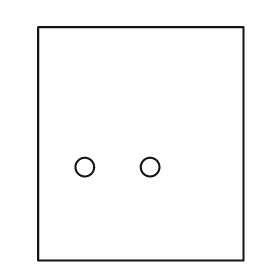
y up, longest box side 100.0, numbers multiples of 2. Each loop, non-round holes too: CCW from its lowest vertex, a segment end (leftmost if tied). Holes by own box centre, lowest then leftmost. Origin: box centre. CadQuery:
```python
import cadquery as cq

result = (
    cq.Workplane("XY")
    .moveTo(-44.0, -50.0)
    .lineTo(44.0, -50.0)
    .lineTo(44.0, 50.0)
    .lineTo(-44.0, 50.0)
    .close()
    .moveTo(-24.0, -10.0)
    .circle(4.0)
    .moveTo(4.0, -10.0)
    .circle(4.0)
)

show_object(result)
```